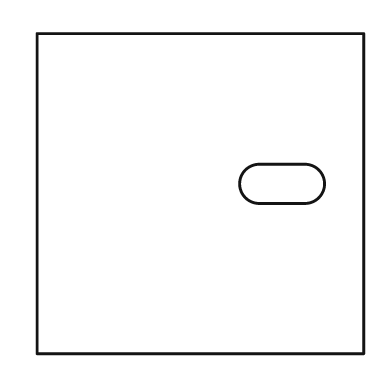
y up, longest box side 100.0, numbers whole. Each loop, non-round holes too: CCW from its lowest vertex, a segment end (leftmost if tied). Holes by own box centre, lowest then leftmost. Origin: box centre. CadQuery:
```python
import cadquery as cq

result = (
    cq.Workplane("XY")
    .moveTo(-50.0, -49.0)
    .lineTo(50.0, -49.0)
    .lineTo(50.0, 49.0)
    .lineTo(-50.0, 49.0)
    .close()
    .moveTo(18.0, -3.0)
    .lineTo(32.0, -3.0)
    .threePointArc((38.0, 3.0), (32.0, 9.0))
    .lineTo(18.0, 9.0)
    .threePointArc((12.0, 3.0), (18.0, -3.0))
    .close()
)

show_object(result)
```